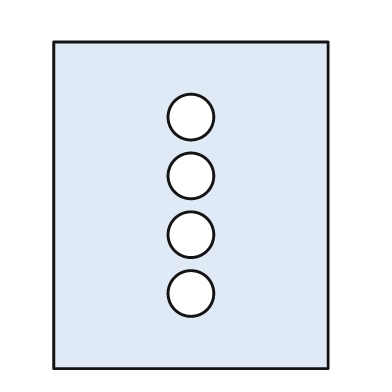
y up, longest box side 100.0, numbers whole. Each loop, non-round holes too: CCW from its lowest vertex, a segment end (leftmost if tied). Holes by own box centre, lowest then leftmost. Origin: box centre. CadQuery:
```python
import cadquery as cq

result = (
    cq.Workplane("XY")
    .moveTo(-42.0, -50.0)
    .lineTo(42.0, -50.0)
    .lineTo(42.0, 50.0)
    .lineTo(-42.0, 50.0)
    .close()
    .moveTo(0.0, -27.0)
    .circle(7.0)
    .moveTo(0.0, -9.0)
    .circle(7.0)
    .moveTo(0.0, 9.0)
    .circle(7.0)
    .moveTo(0.0, 27.0)
    .circle(7.0)
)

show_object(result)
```